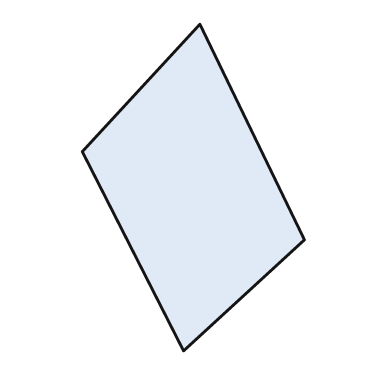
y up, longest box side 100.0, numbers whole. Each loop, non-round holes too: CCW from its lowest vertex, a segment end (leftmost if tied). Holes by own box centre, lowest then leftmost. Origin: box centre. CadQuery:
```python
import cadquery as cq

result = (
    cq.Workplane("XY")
    .moveTo(-3.0, -50.0)
    .lineTo(34.0, -16.0)
    .lineTo(2.0, 50.0)
    .lineTo(-34.0, 11.0)
    .close()
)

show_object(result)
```